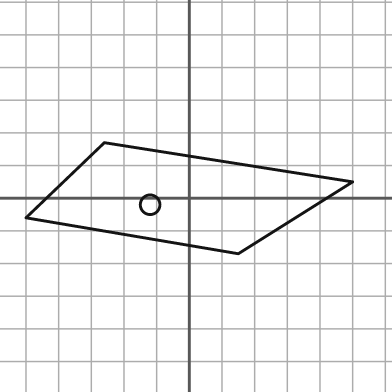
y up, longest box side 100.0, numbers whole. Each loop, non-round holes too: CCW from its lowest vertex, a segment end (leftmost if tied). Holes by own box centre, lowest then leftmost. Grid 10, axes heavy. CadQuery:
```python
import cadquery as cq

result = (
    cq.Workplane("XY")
    .moveTo(15.0, -17.0)
    .lineTo(50.0, 5.0)
    .lineTo(-26.0, 17.0)
    .lineTo(-50.0, -6.0)
    .close()
    .moveTo(-12.0, -2.0)
    .circle(3.0)
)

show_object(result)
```